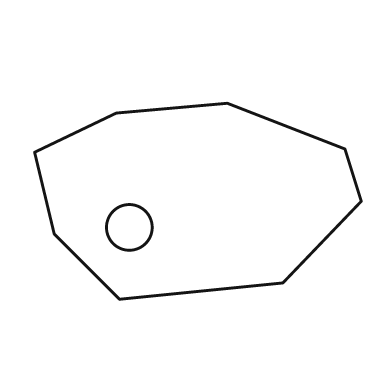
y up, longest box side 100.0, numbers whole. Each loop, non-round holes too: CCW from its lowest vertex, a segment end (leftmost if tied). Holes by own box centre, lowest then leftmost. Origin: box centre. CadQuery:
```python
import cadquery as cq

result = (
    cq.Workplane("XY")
    .moveTo(-24.0, -30.0)
    .lineTo(26.0, -25.0)
    .lineTo(50.0, 0.0)
    .lineTo(45.0, 16.0)
    .lineTo(9.0, 30.0)
    .lineTo(-25.0, 27.0)
    .lineTo(-50.0, 15.0)
    .lineTo(-44.0, -10.0)
    .close()
    .moveTo(-21.0, -8.0)
    .circle(7.0)
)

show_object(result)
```